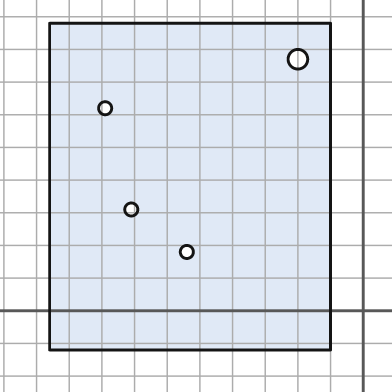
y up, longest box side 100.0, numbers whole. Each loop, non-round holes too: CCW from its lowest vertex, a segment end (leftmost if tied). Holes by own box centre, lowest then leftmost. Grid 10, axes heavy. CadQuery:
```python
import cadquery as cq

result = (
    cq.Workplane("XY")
    .moveTo(-96.0, -12.0)
    .lineTo(-10.0, -12.0)
    .lineTo(-10.0, 88.0)
    .lineTo(-96.0, 88.0)
    .close()
    .moveTo(-54.0, 18.0)
    .circle(2.0)
    .moveTo(-71.0, 31.0)
    .circle(2.0)
    .moveTo(-79.0, 62.0)
    .circle(2.0)
    .moveTo(-20.0, 77.0)
    .circle(3.0)
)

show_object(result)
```